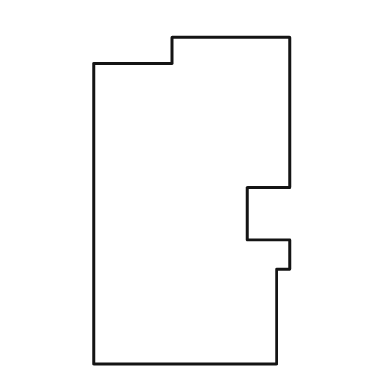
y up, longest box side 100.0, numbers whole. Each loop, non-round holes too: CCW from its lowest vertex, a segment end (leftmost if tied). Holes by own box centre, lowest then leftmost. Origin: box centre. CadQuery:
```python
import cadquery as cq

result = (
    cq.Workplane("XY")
    .moveTo(-30.0, -50.0)
    .lineTo(26.0, -50.0)
    .lineTo(26.0, -21.0)
    .lineTo(30.0, -21.0)
    .lineTo(30.0, -12.0)
    .lineTo(17.0, -12.0)
    .lineTo(17.0, 4.0)
    .lineTo(30.0, 4.0)
    .lineTo(30.0, 50.0)
    .lineTo(-6.0, 50.0)
    .lineTo(-6.0, 42.0)
    .lineTo(-30.0, 42.0)
    .close()
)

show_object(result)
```